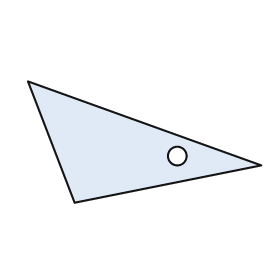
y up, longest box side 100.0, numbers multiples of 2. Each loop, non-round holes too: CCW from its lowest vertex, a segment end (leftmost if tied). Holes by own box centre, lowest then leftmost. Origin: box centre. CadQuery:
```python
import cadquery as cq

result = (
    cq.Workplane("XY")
    .moveTo(-30.0, -26.0)
    .lineTo(50.0, -10.0)
    .lineTo(-50.0, 26.0)
    .close()
    .moveTo(14.0, -6.0)
    .circle(4.0)
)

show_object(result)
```